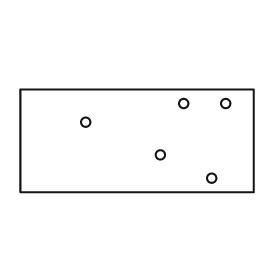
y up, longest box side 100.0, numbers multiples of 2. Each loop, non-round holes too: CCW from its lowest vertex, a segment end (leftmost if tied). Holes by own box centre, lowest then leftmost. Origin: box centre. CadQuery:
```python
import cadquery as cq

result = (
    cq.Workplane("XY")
    .moveTo(-50.0, -22.0)
    .lineTo(50.0, -22.0)
    .lineTo(50.0, 22.0)
    .lineTo(-50.0, 22.0)
    .close()
    .moveTo(32.0, -16.0)
    .circle(2.0)
    .moveTo(10.0, -6.0)
    .circle(2.0)
    .moveTo(-22.0, 8.0)
    .circle(2.0)
    .moveTo(20.0, 16.0)
    .circle(2.0)
    .moveTo(38.0, 16.0)
    .circle(2.0)
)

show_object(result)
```